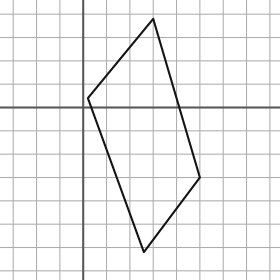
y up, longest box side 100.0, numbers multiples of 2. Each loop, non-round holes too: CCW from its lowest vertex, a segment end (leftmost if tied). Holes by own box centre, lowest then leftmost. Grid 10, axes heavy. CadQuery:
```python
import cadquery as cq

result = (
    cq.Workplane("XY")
    .moveTo(26.0, -62.0)
    .lineTo(50.0, -30.0)
    .lineTo(30.0, 38.0)
    .lineTo(2.0, 4.0)
    .close()
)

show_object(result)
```